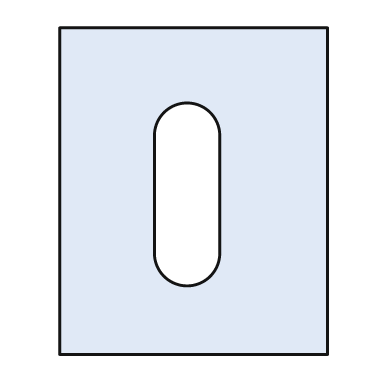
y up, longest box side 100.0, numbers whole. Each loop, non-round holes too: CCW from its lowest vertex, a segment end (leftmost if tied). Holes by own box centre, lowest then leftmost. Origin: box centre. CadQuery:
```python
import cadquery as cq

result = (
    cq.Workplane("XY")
    .moveTo(-41.0, -50.0)
    .lineTo(41.0, -50.0)
    .lineTo(41.0, 50.0)
    .lineTo(-41.0, 50.0)
    .close()
    .moveTo(-12.0, -19.0)
    .threePointArc((-2.0, -29.0), (8.0, -19.0))
    .lineTo(8.0, 17.0)
    .threePointArc((-2.0, 27.0), (-12.0, 17.0))
    .close()
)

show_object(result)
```